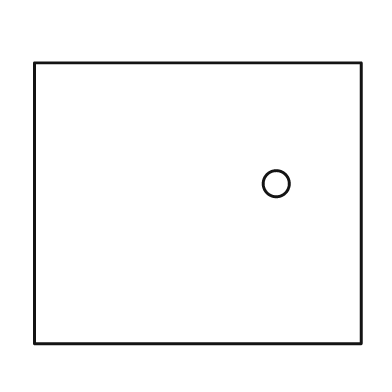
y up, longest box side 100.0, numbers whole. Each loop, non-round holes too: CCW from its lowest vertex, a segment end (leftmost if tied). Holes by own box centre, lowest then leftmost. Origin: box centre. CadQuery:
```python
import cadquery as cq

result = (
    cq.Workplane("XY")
    .moveTo(-50.0, -43.0)
    .lineTo(50.0, -43.0)
    .lineTo(50.0, 43.0)
    .lineTo(-50.0, 43.0)
    .close()
    .moveTo(24.0, 6.0)
    .circle(4.0)
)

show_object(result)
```